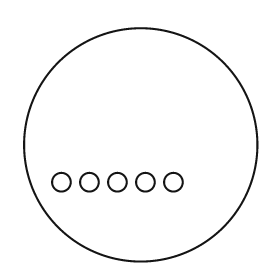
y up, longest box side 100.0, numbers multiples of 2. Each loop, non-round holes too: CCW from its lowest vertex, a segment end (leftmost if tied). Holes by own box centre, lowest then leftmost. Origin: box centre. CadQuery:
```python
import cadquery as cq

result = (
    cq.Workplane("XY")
    .moveTo(0.0, 0.0)
    .circle(50.0)
    .moveTo(-34.0, -16.0)
    .circle(4.0)
    .moveTo(-22.0, -16.0)
    .circle(4.0)
    .moveTo(-10.0, -16.0)
    .circle(4.0)
    .moveTo(2.0, -16.0)
    .circle(4.0)
    .moveTo(14.0, -16.0)
    .circle(4.0)
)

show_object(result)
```